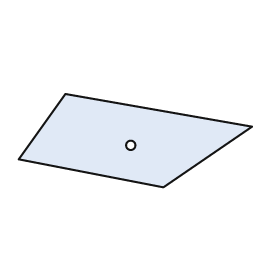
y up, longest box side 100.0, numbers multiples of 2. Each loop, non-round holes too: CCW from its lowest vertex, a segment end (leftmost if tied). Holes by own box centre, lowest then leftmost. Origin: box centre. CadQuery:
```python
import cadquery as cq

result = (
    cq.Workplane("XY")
    .moveTo(12.0, -20.0)
    .lineTo(50.0, 6.0)
    .lineTo(-30.0, 20.0)
    .lineTo(-50.0, -8.0)
    .close()
    .moveTo(-2.0, -2.0)
    .circle(2.0)
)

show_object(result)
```